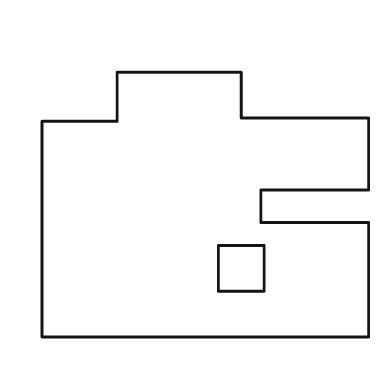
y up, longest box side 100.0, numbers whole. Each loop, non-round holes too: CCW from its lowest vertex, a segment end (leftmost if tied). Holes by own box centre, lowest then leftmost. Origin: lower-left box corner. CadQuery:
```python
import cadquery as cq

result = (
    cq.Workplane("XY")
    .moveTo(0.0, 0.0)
    .lineTo(100.0, 0.0)
    .lineTo(100.0, 35.0)
    .lineTo(67.0, 35.0)
    .lineTo(67.0, 45.0)
    .lineTo(100.0, 45.0)
    .lineTo(100.0, 67.0)
    .lineTo(61.0, 67.0)
    .lineTo(61.0, 81.0)
    .lineTo(23.0, 81.0)
    .lineTo(23.0, 66.0)
    .lineTo(0.0, 66.0)
    .close()
    .moveTo(54.0, 14.0)
    .lineTo(68.0, 14.0)
    .lineTo(68.0, 28.0)
    .lineTo(54.0, 28.0)
    .close()
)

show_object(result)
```